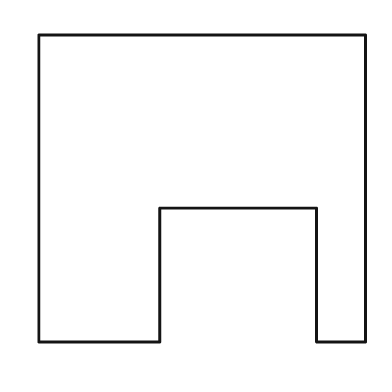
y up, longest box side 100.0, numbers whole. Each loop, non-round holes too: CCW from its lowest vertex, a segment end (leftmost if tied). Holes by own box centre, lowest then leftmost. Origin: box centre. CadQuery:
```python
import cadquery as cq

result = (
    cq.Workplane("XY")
    .moveTo(-50.0, -47.0)
    .lineTo(-13.0, -47.0)
    .lineTo(-13.0, -6.0)
    .lineTo(35.0, -6.0)
    .lineTo(35.0, -47.0)
    .lineTo(50.0, -47.0)
    .lineTo(50.0, 47.0)
    .lineTo(-50.0, 47.0)
    .close()
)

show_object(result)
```